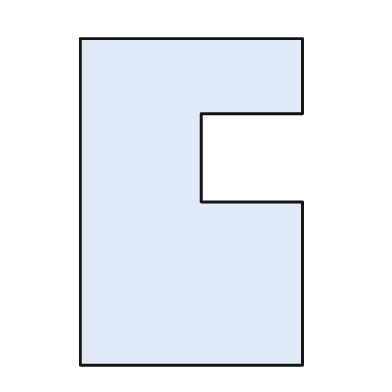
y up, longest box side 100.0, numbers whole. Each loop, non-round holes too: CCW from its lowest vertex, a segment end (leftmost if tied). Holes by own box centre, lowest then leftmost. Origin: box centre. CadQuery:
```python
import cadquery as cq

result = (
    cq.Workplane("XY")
    .moveTo(-34.0, -50.0)
    .lineTo(34.0, -50.0)
    .lineTo(34.0, 0.0)
    .lineTo(3.0, 0.0)
    .lineTo(3.0, 27.0)
    .lineTo(34.0, 27.0)
    .lineTo(34.0, 50.0)
    .lineTo(-34.0, 50.0)
    .close()
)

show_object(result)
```